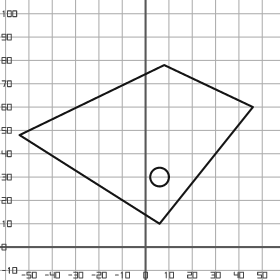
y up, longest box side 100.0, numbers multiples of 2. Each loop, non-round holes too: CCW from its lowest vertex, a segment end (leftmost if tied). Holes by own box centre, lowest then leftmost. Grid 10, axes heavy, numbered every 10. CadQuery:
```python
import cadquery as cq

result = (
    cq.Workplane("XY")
    .moveTo(6.0, 10.0)
    .lineTo(46.0, 60.0)
    .lineTo(8.0, 78.0)
    .lineTo(-54.0, 48.0)
    .close()
    .moveTo(6.0, 30.0)
    .circle(4.0)
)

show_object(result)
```